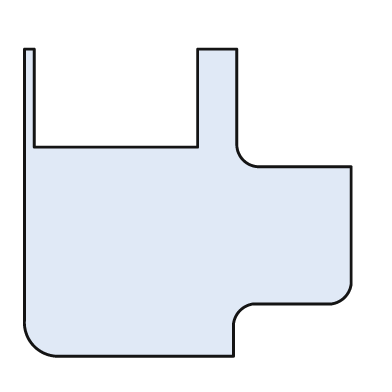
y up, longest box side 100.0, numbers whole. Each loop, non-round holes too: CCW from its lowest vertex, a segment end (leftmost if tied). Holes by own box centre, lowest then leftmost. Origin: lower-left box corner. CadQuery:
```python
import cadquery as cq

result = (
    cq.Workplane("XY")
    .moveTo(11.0, 0.0)
    .lineTo(64.0, 0.0)
    .lineTo(64.0, 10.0)
    .threePointArc((66.0, 14.0), (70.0, 16.0))
    .lineTo(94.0, 16.0)
    .threePointArc((98.0, 18.0), (100.0, 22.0))
    .lineTo(100.0, 58.0)
    .lineTo(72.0, 58.0)
    .threePointArc((67.0, 60.0), (65.0, 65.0))
    .lineTo(65.0, 94.0)
    .lineTo(53.0, 94.0)
    .lineTo(53.0, 64.0)
    .lineTo(3.0, 64.0)
    .lineTo(3.0, 94.0)
    .lineTo(0.0, 94.0)
    .lineTo(0.0, 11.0)
    .threePointArc((3.0, 3.0), (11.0, 0.0))
    .close()
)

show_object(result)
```